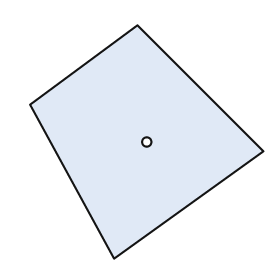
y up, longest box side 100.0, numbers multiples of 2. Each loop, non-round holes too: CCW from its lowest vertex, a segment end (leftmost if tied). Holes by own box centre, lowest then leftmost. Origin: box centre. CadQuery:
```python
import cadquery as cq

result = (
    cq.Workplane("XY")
    .moveTo(-14.0, -50.0)
    .lineTo(50.0, -4.0)
    .lineTo(-4.0, 50.0)
    .lineTo(-50.0, 16.0)
    .close()
    .moveTo(0.0, 0.0)
    .circle(2.0)
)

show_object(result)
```